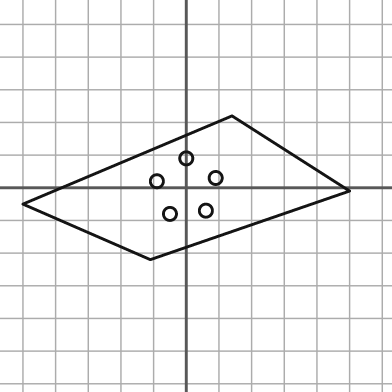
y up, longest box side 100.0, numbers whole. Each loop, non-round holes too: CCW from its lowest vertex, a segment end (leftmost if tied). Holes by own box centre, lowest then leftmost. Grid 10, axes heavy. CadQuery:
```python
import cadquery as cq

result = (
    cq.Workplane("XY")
    .moveTo(-11.0, -22.0)
    .lineTo(50.0, -1.0)
    .lineTo(14.0, 22.0)
    .lineTo(-50.0, -5.0)
    .close()
    .moveTo(-5.0, -8.0)
    .circle(2.0)
    .moveTo(6.0, -7.0)
    .circle(2.0)
    .moveTo(-9.0, 2.0)
    .circle(2.0)
    .moveTo(9.0, 3.0)
    .circle(2.0)
    .moveTo(0.0, 9.0)
    .circle(2.0)
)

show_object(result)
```